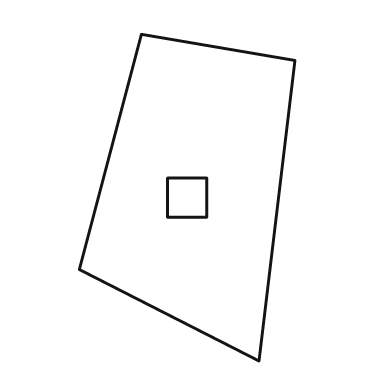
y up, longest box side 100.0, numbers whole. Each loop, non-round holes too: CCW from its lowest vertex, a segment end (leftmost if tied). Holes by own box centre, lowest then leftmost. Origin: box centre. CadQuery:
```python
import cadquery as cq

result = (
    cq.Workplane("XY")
    .moveTo(22.0, -50.0)
    .lineTo(33.0, 42.0)
    .lineTo(-14.0, 50.0)
    .lineTo(-33.0, -22.0)
    .close()
    .moveTo(-6.0, -6.0)
    .lineTo(6.0, -6.0)
    .lineTo(6.0, 6.0)
    .lineTo(-6.0, 6.0)
    .close()
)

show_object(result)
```